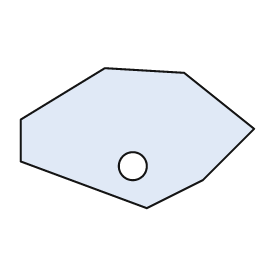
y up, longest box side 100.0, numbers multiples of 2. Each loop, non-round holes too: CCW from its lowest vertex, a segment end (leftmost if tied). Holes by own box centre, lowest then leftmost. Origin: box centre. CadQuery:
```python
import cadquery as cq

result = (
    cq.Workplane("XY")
    .moveTo(4.0, -30.0)
    .lineTo(28.0, -18.0)
    .lineTo(50.0, 4.0)
    .lineTo(20.0, 28.0)
    .lineTo(-14.0, 30.0)
    .lineTo(-50.0, 8.0)
    .lineTo(-50.0, -10.0)
    .close()
    .moveTo(-2.0, -12.0)
    .circle(6.0)
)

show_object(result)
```